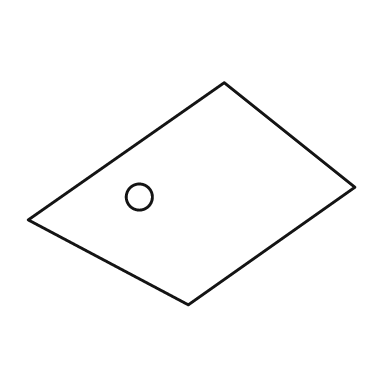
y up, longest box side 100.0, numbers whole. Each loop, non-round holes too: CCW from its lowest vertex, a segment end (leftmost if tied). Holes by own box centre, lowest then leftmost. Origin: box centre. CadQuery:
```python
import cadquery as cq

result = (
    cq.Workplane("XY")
    .moveTo(-1.0, -34.0)
    .lineTo(50.0, 2.0)
    .lineTo(10.0, 34.0)
    .lineTo(-50.0, -8.0)
    .close()
    .moveTo(-16.0, -1.0)
    .circle(4.0)
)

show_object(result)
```